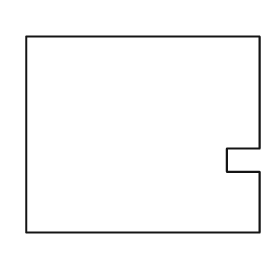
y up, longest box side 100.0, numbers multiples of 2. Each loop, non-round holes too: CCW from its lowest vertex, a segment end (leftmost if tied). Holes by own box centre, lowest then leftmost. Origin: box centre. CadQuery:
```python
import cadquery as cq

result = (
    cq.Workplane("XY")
    .moveTo(-50.0, -42.0)
    .lineTo(50.0, -42.0)
    .lineTo(50.0, -16.0)
    .lineTo(36.0, -16.0)
    .lineTo(36.0, -6.0)
    .lineTo(50.0, -6.0)
    .lineTo(50.0, 42.0)
    .lineTo(-50.0, 42.0)
    .close()
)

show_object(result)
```